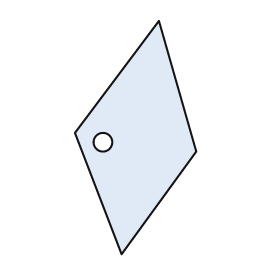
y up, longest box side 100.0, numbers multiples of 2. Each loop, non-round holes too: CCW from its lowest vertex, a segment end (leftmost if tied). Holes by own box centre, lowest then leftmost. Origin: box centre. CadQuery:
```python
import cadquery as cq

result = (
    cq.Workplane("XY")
    .moveTo(-6.0, -50.0)
    .lineTo(26.0, -6.0)
    .lineTo(10.0, 50.0)
    .lineTo(-26.0, 2.0)
    .close()
    .moveTo(-14.0, -2.0)
    .circle(4.0)
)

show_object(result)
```